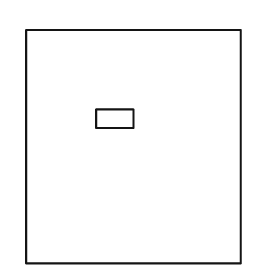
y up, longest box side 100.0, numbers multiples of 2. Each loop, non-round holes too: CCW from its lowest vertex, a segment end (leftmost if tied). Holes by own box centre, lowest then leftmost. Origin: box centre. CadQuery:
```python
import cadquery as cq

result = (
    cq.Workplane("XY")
    .moveTo(-46.0, -50.0)
    .lineTo(46.0, -50.0)
    .lineTo(46.0, 50.0)
    .lineTo(-46.0, 50.0)
    .close()
    .moveTo(-16.0, 8.0)
    .lineTo(0.0, 8.0)
    .lineTo(0.0, 16.0)
    .lineTo(-16.0, 16.0)
    .close()
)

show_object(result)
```